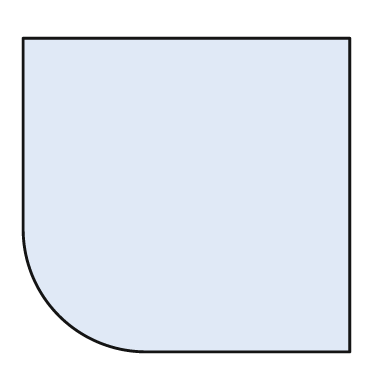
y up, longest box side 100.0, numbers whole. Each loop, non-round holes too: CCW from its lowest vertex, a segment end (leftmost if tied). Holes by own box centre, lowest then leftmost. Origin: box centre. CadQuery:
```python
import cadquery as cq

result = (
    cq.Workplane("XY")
    .moveTo(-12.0, -48.0)
    .lineTo(50.0, -48.0)
    .lineTo(50.0, 48.0)
    .lineTo(-50.0, 48.0)
    .lineTo(-50.0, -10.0)
    .threePointArc((-39.0, -37.0), (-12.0, -48.0))
    .close()
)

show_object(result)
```